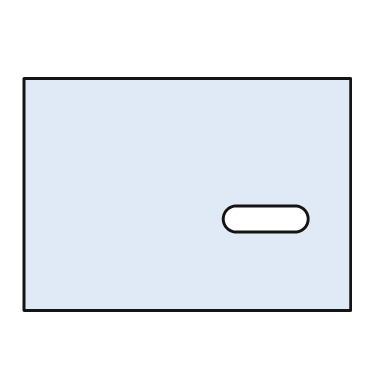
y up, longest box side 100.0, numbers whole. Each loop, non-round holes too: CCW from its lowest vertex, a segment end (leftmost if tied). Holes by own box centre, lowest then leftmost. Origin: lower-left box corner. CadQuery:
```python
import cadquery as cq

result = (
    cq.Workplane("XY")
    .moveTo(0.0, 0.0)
    .lineTo(100.0, 0.0)
    .lineTo(100.0, 71.0)
    .lineTo(0.0, 71.0)
    .close()
    .moveTo(65.0, 24.0)
    .lineTo(83.0, 24.0)
    .threePointArc((87.0, 28.0), (83.0, 32.0))
    .lineTo(65.0, 32.0)
    .threePointArc((61.0, 28.0), (65.0, 24.0))
    .close()
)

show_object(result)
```